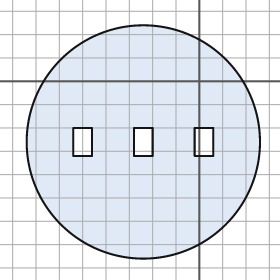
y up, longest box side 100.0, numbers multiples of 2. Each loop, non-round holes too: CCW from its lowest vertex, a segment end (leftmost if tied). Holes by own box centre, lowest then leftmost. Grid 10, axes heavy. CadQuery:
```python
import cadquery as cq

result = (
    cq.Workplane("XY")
    .moveTo(-24.0, -26.0)
    .circle(50.0)
    .moveTo(-54.0, -32.0)
    .lineTo(-46.0, -32.0)
    .lineTo(-46.0, -20.0)
    .lineTo(-54.0, -20.0)
    .close()
    .moveTo(-28.0, -32.0)
    .lineTo(-20.0, -32.0)
    .lineTo(-20.0, -20.0)
    .lineTo(-28.0, -20.0)
    .close()
    .moveTo(-2.0, -32.0)
    .lineTo(6.0, -32.0)
    .lineTo(6.0, -20.0)
    .lineTo(-2.0, -20.0)
    .close()
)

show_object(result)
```